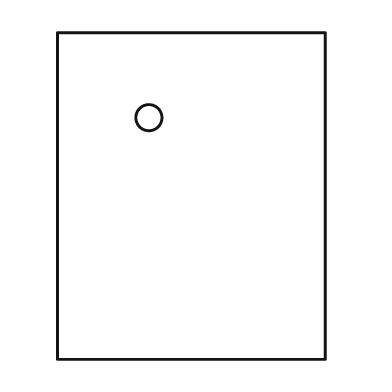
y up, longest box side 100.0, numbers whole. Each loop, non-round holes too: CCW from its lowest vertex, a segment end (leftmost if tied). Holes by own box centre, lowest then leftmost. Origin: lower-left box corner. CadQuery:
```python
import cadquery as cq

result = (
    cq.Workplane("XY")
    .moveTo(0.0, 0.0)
    .lineTo(82.0, 0.0)
    .lineTo(82.0, 100.0)
    .lineTo(0.0, 100.0)
    .close()
    .moveTo(28.0, 74.0)
    .circle(4.0)
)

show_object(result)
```